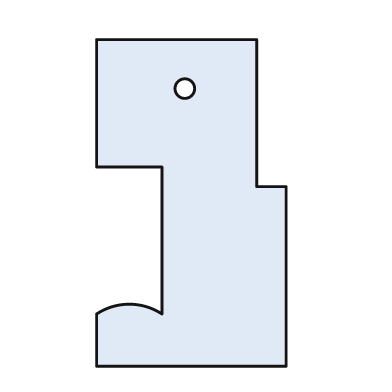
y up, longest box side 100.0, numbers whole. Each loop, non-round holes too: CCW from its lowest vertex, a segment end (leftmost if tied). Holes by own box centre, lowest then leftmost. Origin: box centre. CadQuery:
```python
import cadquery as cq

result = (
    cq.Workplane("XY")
    .moveTo(-29.0, -50.0)
    .lineTo(29.0, -50.0)
    .lineTo(29.0, 5.0)
    .lineTo(20.0, 5.0)
    .lineTo(20.0, 50.0)
    .lineTo(-29.0, 50.0)
    .lineTo(-29.0, 11.0)
    .lineTo(-9.0, 11.0)
    .lineTo(-9.0, -34.0)
    .threePointArc((-19.0, -31.0), (-29.0, -34.0))
    .close()
    .moveTo(-2.0, 35.0)
    .circle(3.0)
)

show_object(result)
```